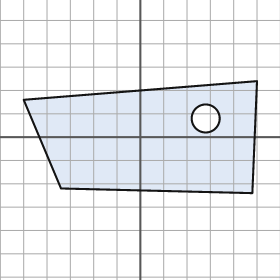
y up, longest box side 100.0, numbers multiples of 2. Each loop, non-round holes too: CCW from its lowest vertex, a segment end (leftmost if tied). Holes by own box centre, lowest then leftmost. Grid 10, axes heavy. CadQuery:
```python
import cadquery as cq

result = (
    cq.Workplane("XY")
    .moveTo(48.0, -24.0)
    .lineTo(50.0, 24.0)
    .lineTo(-50.0, 16.0)
    .lineTo(-34.0, -22.0)
    .close()
    .moveTo(28.0, 8.0)
    .circle(6.0)
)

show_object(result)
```